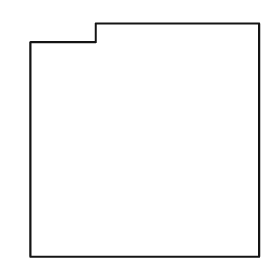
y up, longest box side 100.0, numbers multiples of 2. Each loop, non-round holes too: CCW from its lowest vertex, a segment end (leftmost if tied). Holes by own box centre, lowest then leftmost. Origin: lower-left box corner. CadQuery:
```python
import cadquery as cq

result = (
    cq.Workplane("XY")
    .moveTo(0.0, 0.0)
    .lineTo(98.0, 0.0)
    .lineTo(98.0, 100.0)
    .lineTo(28.0, 100.0)
    .lineTo(28.0, 92.0)
    .lineTo(0.0, 92.0)
    .close()
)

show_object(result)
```